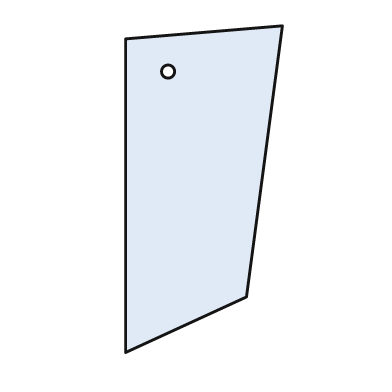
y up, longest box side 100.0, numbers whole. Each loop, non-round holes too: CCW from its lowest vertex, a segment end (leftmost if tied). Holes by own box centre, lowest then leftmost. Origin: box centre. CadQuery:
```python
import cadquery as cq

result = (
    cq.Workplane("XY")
    .moveTo(-24.0, -50.0)
    .lineTo(13.0, -33.0)
    .lineTo(24.0, 50.0)
    .lineTo(-24.0, 46.0)
    .close()
    .moveTo(-11.0, 36.0)
    .circle(2.0)
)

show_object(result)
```